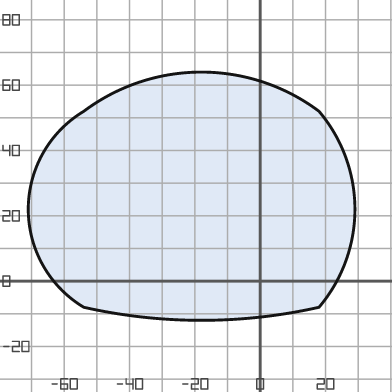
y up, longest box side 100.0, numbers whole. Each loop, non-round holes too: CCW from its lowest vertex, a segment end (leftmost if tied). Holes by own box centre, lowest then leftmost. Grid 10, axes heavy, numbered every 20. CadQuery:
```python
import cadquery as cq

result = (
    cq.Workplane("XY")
    .moveTo(-54.0, -8.0)
    .threePointArc((-18.0, -12.0), (18.0, -8.0))
    .threePointArc((29.0, 22.0), (18.0, 52.0))
    .threePointArc((-18.0, 64.0), (-54.0, 52.0))
    .threePointArc((-71.0, 22.0), (-54.0, -8.0))
    .close()
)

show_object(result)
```